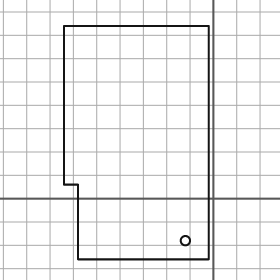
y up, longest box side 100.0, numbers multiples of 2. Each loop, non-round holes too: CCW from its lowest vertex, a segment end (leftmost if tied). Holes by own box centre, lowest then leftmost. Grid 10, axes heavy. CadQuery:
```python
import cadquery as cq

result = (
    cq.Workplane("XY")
    .moveTo(-58.0, -26.0)
    .lineTo(-2.0, -26.0)
    .lineTo(-2.0, 74.0)
    .lineTo(-64.0, 74.0)
    .lineTo(-64.0, 6.0)
    .lineTo(-58.0, 6.0)
    .close()
    .moveTo(-12.0, -18.0)
    .circle(2.0)
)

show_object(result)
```